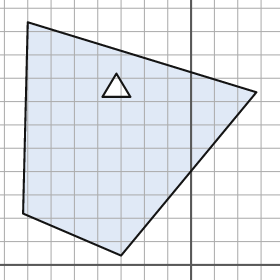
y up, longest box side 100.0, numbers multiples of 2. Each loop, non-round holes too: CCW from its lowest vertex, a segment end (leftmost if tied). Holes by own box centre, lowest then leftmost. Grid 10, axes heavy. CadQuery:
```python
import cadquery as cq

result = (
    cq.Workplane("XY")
    .moveTo(-30.0, 4.0)
    .lineTo(28.0, 74.0)
    .lineTo(-70.0, 104.0)
    .lineTo(-72.0, 22.0)
    .close()
    .moveTo(-38.0, 72.0)
    .lineTo(-26.0, 72.0)
    .lineTo(-32.0, 82.0)
    .close()
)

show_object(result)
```